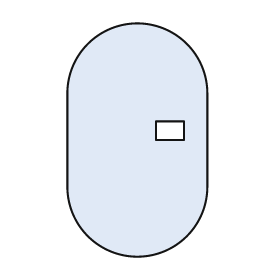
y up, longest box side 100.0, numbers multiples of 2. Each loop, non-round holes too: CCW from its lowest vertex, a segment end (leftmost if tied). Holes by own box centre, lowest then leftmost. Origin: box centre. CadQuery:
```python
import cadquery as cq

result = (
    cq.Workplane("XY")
    .moveTo(-30.0, -20.0)
    .threePointArc((0.0, -50.0), (30.0, -20.0))
    .lineTo(30.0, 20.0)
    .threePointArc((0.0, 50.0), (-30.0, 20.0))
    .close()
    .moveTo(8.0, 0.0)
    .lineTo(20.0, 0.0)
    .lineTo(20.0, 8.0)
    .lineTo(8.0, 8.0)
    .close()
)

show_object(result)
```